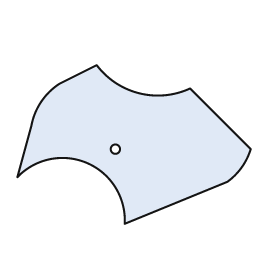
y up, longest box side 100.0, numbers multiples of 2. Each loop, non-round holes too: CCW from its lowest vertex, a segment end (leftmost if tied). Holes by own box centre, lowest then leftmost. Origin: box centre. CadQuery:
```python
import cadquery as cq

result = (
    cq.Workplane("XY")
    .moveTo(-4.0, -34.0)
    .lineTo(40.0, -16.0)
    .threePointArc((46.0, -10.0), (50.0, -2.0))
    .lineTo(24.0, 24.0)
    .threePointArc((2.0, 22.0), (-16.0, 34.0))
    .lineTo(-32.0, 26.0)
    .threePointArc((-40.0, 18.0), (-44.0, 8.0))
    .lineTo(-50.0, -14.0)
    .threePointArc((-20.0, -8.0), (-4.0, -34.0))
    .close()
    .moveTo(-8.0, -2.0)
    .circle(2.0)
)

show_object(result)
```